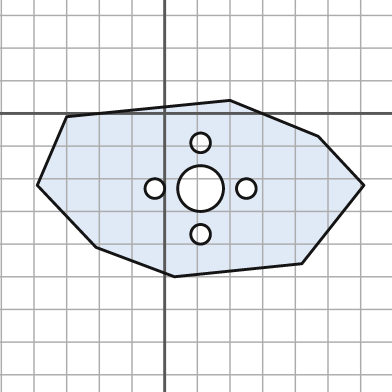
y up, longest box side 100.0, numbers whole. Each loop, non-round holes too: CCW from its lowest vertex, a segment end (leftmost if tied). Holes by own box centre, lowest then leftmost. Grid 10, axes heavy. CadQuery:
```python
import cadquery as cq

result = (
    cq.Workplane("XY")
    .moveTo(3.0, -50.0)
    .lineTo(42.0, -46.0)
    .lineTo(61.0, -22.0)
    .lineTo(47.0, -7.0)
    .lineTo(20.0, 4.0)
    .lineTo(-30.0, -1.0)
    .lineTo(-39.0, -22.0)
    .lineTo(-21.0, -41.0)
    .close()
    .moveTo(11.0, -37.0)
    .circle(3.0)
    .moveTo(-3.0, -23.0)
    .circle(3.0)
    .moveTo(11.0, -23.0)
    .circle(7.0)
    .moveTo(25.0, -23.0)
    .circle(3.0)
    .moveTo(11.0, -9.0)
    .circle(3.0)
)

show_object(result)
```